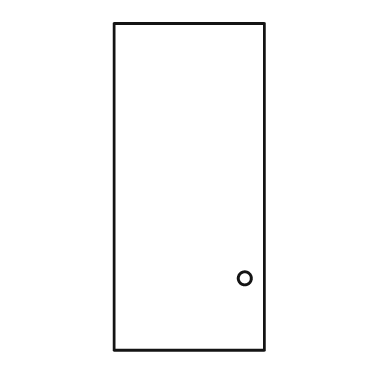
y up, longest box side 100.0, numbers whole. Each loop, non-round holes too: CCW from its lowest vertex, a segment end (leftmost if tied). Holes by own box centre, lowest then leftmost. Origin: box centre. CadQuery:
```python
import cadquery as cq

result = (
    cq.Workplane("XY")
    .moveTo(-23.0, -50.0)
    .lineTo(23.0, -50.0)
    .lineTo(23.0, 50.0)
    .lineTo(-23.0, 50.0)
    .close()
    .moveTo(17.0, -28.0)
    .circle(2.0)
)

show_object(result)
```